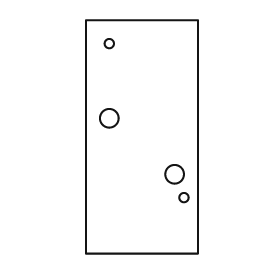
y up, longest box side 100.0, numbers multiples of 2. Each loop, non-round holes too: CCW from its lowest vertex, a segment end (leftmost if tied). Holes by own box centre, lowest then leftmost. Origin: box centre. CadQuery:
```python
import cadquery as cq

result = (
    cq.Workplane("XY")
    .moveTo(-24.0, -50.0)
    .lineTo(24.0, -50.0)
    .lineTo(24.0, 50.0)
    .lineTo(-24.0, 50.0)
    .close()
    .moveTo(18.0, -26.0)
    .circle(2.0)
    .moveTo(14.0, -16.0)
    .circle(4.0)
    .moveTo(-14.0, 8.0)
    .circle(4.0)
    .moveTo(-14.0, 40.0)
    .circle(2.0)
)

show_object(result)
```